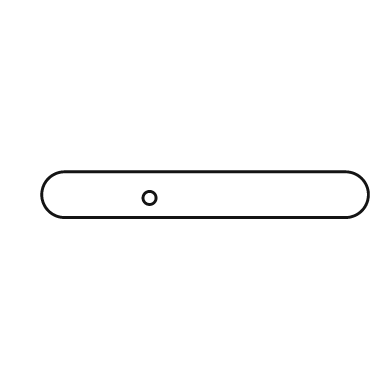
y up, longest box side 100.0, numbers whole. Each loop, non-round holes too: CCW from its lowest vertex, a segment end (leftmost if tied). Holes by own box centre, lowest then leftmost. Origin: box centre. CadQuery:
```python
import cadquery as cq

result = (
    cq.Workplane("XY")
    .moveTo(-43.0, -7.0)
    .lineTo(43.0, -7.0)
    .threePointArc((50.0, 0.0), (43.0, 7.0))
    .lineTo(-43.0, 7.0)
    .threePointArc((-50.0, 0.0), (-43.0, -7.0))
    .close()
    .moveTo(-17.0, -1.0)
    .circle(2.0)
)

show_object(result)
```